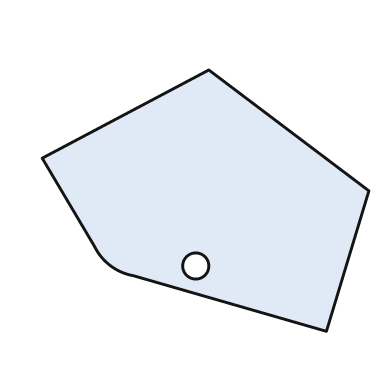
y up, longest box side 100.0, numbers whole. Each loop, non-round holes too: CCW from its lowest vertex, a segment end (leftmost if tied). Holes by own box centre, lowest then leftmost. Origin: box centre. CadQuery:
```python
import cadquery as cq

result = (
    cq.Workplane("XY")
    .moveTo(37.0, -40.0)
    .lineTo(50.0, 3.0)
    .lineTo(1.0, 40.0)
    .lineTo(-50.0, 13.0)
    .lineTo(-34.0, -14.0)
    .threePointArc((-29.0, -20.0), (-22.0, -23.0))
    .close()
    .moveTo(-3.0, -20.0)
    .circle(4.0)
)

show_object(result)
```